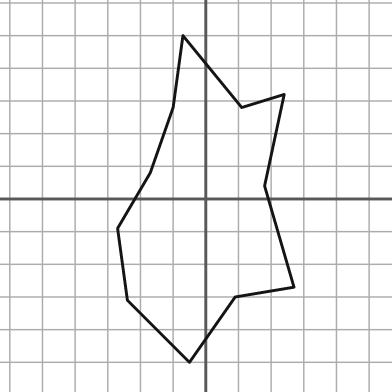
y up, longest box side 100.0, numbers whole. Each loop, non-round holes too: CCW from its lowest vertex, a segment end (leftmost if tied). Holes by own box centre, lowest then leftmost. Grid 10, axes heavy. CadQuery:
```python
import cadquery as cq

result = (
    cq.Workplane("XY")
    .moveTo(-5.0, -50.0)
    .lineTo(9.0, -30.0)
    .lineTo(27.0, -27.0)
    .lineTo(18.0, 4.0)
    .lineTo(24.0, 32.0)
    .lineTo(11.0, 28.0)
    .lineTo(-7.0, 50.0)
    .lineTo(-10.0, 28.0)
    .lineTo(-17.0, 8.0)
    .lineTo(-27.0, -9.0)
    .lineTo(-24.0, -31.0)
    .close()
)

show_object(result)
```